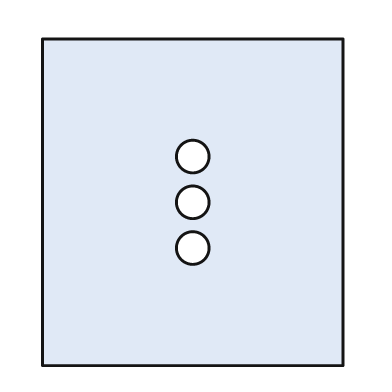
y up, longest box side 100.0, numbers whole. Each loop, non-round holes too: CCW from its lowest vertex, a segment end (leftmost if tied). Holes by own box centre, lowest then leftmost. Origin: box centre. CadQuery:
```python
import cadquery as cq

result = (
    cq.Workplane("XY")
    .moveTo(-46.0, -50.0)
    .lineTo(46.0, -50.0)
    .lineTo(46.0, 50.0)
    .lineTo(-46.0, 50.0)
    .close()
    .moveTo(0.0, -14.0)
    .circle(5.0)
    .moveTo(0.0, 0.0)
    .circle(5.0)
    .moveTo(0.0, 14.0)
    .circle(5.0)
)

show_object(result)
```